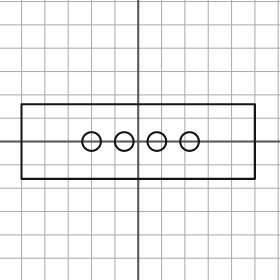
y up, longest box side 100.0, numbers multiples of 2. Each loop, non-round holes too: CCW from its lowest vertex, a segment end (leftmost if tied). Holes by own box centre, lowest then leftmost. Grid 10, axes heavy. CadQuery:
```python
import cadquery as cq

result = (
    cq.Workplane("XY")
    .moveTo(-50.0, -16.0)
    .lineTo(50.0, -16.0)
    .lineTo(50.0, 16.0)
    .lineTo(-50.0, 16.0)
    .close()
    .moveTo(-20.0, 0.0)
    .circle(4.0)
    .moveTo(-6.0, 0.0)
    .circle(4.0)
    .moveTo(8.0, 0.0)
    .circle(4.0)
    .moveTo(22.0, 0.0)
    .circle(4.0)
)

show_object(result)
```